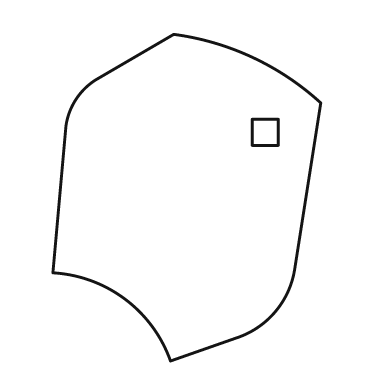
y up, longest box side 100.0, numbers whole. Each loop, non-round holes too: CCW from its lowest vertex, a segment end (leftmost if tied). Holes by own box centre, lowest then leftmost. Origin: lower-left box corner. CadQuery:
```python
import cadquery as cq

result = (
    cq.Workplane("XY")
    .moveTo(36.0, 0.0)
    .lineTo(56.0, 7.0)
    .threePointArc((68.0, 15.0), (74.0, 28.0))
    .lineTo(82.0, 79.0)
    .threePointArc((61.0, 93.0), (37.0, 100.0))
    .lineTo(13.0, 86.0)
    .threePointArc((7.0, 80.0), (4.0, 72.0))
    .lineTo(0.0, 27.0)
    .threePointArc((22.0, 19.0), (36.0, 0.0))
    .close()
    .moveTo(61.0, 66.0)
    .lineTo(69.0, 66.0)
    .lineTo(69.0, 74.0)
    .lineTo(61.0, 74.0)
    .close()
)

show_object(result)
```